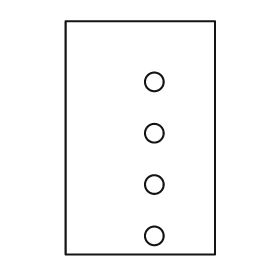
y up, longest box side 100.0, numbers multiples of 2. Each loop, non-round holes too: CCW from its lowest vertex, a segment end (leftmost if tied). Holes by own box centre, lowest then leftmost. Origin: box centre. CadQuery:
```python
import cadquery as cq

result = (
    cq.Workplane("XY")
    .moveTo(-32.0, -50.0)
    .lineTo(32.0, -50.0)
    .lineTo(32.0, 50.0)
    .lineTo(-32.0, 50.0)
    .close()
    .moveTo(6.0, -42.0)
    .circle(4.0)
    .moveTo(6.0, -20.0)
    .circle(4.0)
    .moveTo(6.0, 2.0)
    .circle(4.0)
    .moveTo(6.0, 24.0)
    .circle(4.0)
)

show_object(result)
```